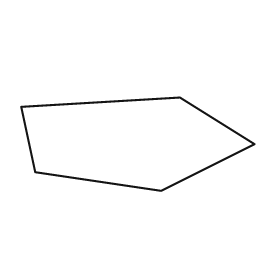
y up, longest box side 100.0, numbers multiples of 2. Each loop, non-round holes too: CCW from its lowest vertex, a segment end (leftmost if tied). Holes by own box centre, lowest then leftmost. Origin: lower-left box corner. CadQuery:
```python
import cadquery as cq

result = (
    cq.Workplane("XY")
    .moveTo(60.0, 0.0)
    .lineTo(100.0, 20.0)
    .lineTo(68.0, 40.0)
    .lineTo(0.0, 36.0)
    .lineTo(6.0, 8.0)
    .close()
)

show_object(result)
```